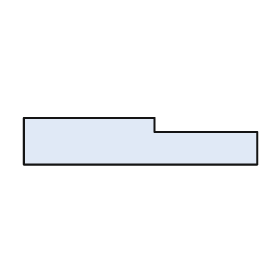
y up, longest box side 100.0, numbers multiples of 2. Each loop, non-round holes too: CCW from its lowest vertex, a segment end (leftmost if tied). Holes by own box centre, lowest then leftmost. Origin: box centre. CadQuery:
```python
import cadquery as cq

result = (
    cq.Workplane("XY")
    .moveTo(-50.0, -10.0)
    .lineTo(50.0, -10.0)
    .lineTo(50.0, 4.0)
    .lineTo(6.0, 4.0)
    .lineTo(6.0, 10.0)
    .lineTo(-50.0, 10.0)
    .close()
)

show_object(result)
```